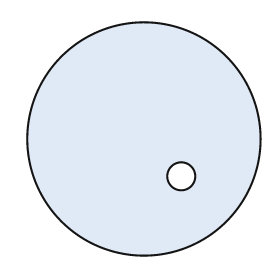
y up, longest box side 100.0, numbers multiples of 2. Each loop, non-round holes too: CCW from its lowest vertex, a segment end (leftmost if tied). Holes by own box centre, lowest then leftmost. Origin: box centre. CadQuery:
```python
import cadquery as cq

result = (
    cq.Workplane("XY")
    .moveTo(0.0, 0.0)
    .circle(50.0)
    .moveTo(16.0, -16.0)
    .circle(6.0)
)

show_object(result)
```